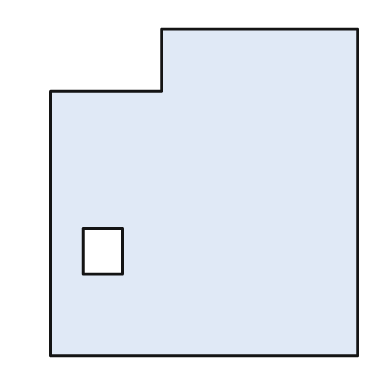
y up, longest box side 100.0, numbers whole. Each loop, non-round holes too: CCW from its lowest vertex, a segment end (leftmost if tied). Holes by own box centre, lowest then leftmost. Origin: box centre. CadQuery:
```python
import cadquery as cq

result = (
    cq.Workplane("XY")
    .moveTo(-47.0, -50.0)
    .lineTo(47.0, -50.0)
    .lineTo(47.0, 50.0)
    .lineTo(-13.0, 50.0)
    .lineTo(-13.0, 31.0)
    .lineTo(-47.0, 31.0)
    .close()
    .moveTo(-37.0, -25.0)
    .lineTo(-25.0, -25.0)
    .lineTo(-25.0, -11.0)
    .lineTo(-37.0, -11.0)
    .close()
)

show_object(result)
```